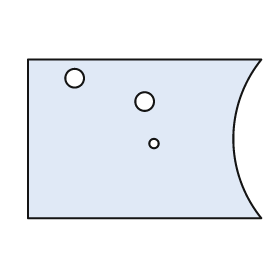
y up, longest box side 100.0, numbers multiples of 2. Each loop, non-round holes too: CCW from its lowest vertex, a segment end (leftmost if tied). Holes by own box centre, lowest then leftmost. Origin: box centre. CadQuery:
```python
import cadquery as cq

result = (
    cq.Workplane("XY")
    .moveTo(-50.0, -34.0)
    .lineTo(50.0, -34.0)
    .threePointArc((38.0, 0.0), (50.0, 34.0))
    .lineTo(-50.0, 34.0)
    .close()
    .moveTo(4.0, -2.0)
    .circle(2.0)
    .moveTo(0.0, 16.0)
    .circle(4.0)
    .moveTo(-30.0, 26.0)
    .circle(4.0)
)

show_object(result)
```